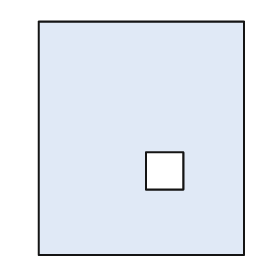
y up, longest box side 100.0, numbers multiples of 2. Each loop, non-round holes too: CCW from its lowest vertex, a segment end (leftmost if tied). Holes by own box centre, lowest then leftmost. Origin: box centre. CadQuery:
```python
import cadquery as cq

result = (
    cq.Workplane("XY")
    .moveTo(-44.0, -50.0)
    .lineTo(44.0, -50.0)
    .lineTo(44.0, 50.0)
    .lineTo(-44.0, 50.0)
    .close()
    .moveTo(2.0, -22.0)
    .lineTo(18.0, -22.0)
    .lineTo(18.0, -6.0)
    .lineTo(2.0, -6.0)
    .close()
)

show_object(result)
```